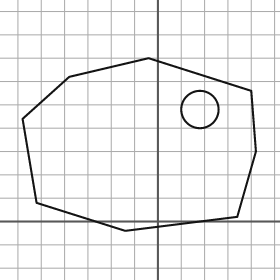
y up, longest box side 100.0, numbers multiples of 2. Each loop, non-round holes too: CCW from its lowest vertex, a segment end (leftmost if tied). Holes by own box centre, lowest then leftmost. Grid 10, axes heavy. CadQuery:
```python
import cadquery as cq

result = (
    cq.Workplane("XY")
    .moveTo(-14.0, -4.0)
    .lineTo(34.0, 2.0)
    .lineTo(42.0, 30.0)
    .lineTo(40.0, 56.0)
    .lineTo(-4.0, 70.0)
    .lineTo(-38.0, 62.0)
    .lineTo(-58.0, 44.0)
    .lineTo(-52.0, 8.0)
    .close()
    .moveTo(18.0, 48.0)
    .circle(8.0)
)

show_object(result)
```